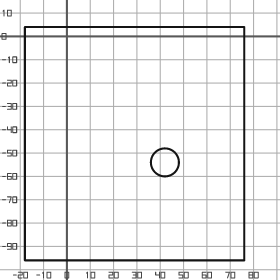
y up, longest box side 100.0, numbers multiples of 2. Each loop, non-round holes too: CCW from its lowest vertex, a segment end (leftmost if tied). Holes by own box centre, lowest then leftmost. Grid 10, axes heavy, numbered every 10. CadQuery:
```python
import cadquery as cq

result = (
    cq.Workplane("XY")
    .moveTo(-18.0, -96.0)
    .lineTo(76.0, -96.0)
    .lineTo(76.0, 4.0)
    .lineTo(-18.0, 4.0)
    .close()
    .moveTo(42.0, -54.0)
    .circle(6.0)
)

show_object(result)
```